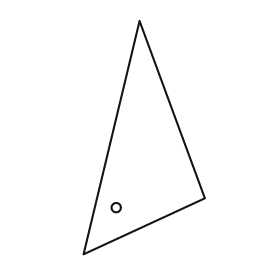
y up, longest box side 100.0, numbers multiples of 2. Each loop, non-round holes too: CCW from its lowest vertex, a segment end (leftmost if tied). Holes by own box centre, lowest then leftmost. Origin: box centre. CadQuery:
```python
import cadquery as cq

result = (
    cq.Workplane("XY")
    .moveTo(-26.0, -50.0)
    .lineTo(26.0, -26.0)
    .lineTo(-2.0, 50.0)
    .close()
    .moveTo(-12.0, -30.0)
    .circle(2.0)
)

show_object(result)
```